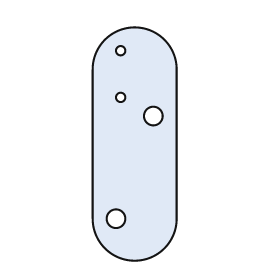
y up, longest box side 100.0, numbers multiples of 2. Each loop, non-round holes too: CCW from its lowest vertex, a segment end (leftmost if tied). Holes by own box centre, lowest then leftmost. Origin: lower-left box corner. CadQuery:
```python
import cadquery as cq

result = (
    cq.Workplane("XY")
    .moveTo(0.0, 18.0)
    .threePointArc((18.0, 0.0), (36.0, 18.0))
    .lineTo(36.0, 82.0)
    .threePointArc((18.0, 100.0), (0.0, 82.0))
    .close()
    .moveTo(10.0, 18.0)
    .circle(4.0)
    .moveTo(26.0, 62.0)
    .circle(4.0)
    .moveTo(12.0, 70.0)
    .circle(2.0)
    .moveTo(12.0, 90.0)
    .circle(2.0)
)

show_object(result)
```